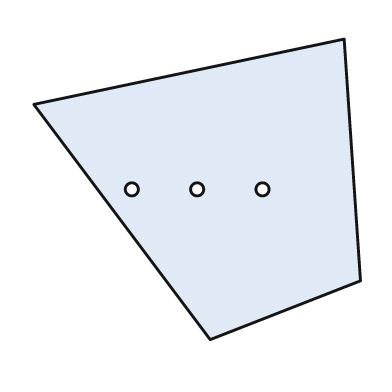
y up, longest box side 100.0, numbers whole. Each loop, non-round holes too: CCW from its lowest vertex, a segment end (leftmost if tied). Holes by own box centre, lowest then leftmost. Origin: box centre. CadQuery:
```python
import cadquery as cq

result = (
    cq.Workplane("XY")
    .moveTo(4.0, -46.0)
    .lineTo(50.0, -28.0)
    .lineTo(45.0, 46.0)
    .lineTo(-50.0, 26.0)
    .close()
    .moveTo(-20.0, 0.0)
    .circle(2.0)
    .moveTo(0.0, 0.0)
    .circle(2.0)
    .moveTo(20.0, 0.0)
    .circle(2.0)
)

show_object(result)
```